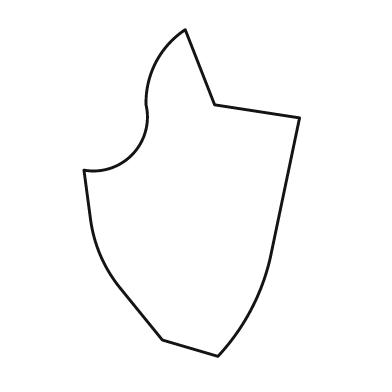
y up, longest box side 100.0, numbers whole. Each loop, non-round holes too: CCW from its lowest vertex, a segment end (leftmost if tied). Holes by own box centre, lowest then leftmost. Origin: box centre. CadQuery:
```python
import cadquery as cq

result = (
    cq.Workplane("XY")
    .moveTo(8.0, -50.0)
    .threePointArc((18.0, -36.0), (24.0, -20.0))
    .lineTo(33.0, 23.0)
    .lineTo(7.0, 27.0)
    .lineTo(-2.0, 50.0)
    .threePointArc((-11.0, 40.0), (-14.0, 27.0))
    .threePointArc((-18.0, 12.0), (-33.0, 7.0))
    .lineTo(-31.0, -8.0)
    .threePointArc((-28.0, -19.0), (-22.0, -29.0))
    .lineTo(-9.0, -45.0)
    .close()
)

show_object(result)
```